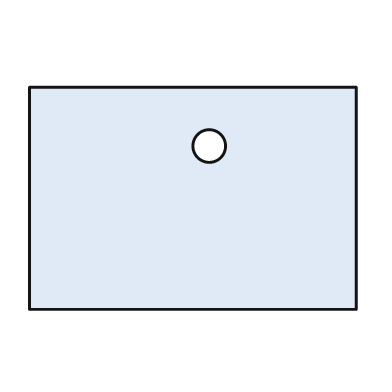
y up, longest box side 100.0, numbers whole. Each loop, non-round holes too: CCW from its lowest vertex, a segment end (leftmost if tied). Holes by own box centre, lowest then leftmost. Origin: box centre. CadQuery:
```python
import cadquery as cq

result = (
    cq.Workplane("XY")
    .moveTo(-50.0, -34.0)
    .lineTo(50.0, -34.0)
    .lineTo(50.0, 34.0)
    .lineTo(-50.0, 34.0)
    .close()
    .moveTo(5.0, 16.0)
    .circle(5.0)
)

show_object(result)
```